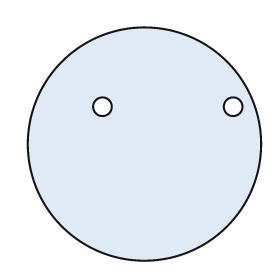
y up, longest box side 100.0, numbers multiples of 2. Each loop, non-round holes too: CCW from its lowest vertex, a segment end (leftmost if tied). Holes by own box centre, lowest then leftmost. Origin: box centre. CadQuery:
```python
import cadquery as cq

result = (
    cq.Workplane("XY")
    .moveTo(0.0, 0.0)
    .circle(50.0)
    .moveTo(-18.0, 16.0)
    .circle(4.0)
    .moveTo(38.0, 16.0)
    .circle(4.0)
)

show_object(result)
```